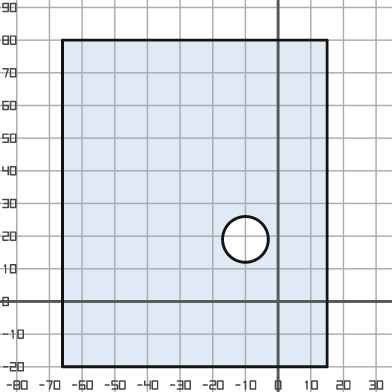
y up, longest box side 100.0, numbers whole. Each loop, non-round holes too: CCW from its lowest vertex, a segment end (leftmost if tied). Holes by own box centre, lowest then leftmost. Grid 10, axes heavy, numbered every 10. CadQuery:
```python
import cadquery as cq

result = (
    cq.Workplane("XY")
    .moveTo(-66.0, -20.0)
    .lineTo(15.0, -20.0)
    .lineTo(15.0, 80.0)
    .lineTo(-66.0, 80.0)
    .close()
    .moveTo(-10.0, 19.0)
    .circle(7.0)
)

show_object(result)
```